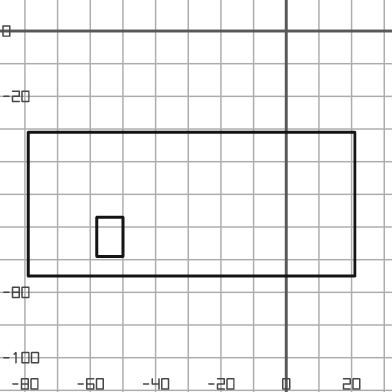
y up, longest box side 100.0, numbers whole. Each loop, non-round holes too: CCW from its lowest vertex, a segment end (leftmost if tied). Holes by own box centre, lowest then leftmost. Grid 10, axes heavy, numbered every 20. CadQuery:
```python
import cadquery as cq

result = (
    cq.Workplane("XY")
    .moveTo(-79.0, -75.0)
    .lineTo(21.0, -75.0)
    .lineTo(21.0, -31.0)
    .lineTo(-79.0, -31.0)
    .close()
    .moveTo(-58.0, -69.0)
    .lineTo(-50.0, -69.0)
    .lineTo(-50.0, -57.0)
    .lineTo(-58.0, -57.0)
    .close()
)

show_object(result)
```